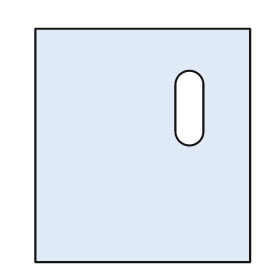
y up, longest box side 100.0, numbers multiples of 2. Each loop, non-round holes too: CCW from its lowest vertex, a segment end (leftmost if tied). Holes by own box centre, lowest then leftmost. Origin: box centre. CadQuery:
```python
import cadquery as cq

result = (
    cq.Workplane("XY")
    .moveTo(-46.0, -50.0)
    .lineTo(46.0, -50.0)
    .lineTo(46.0, 50.0)
    .lineTo(-46.0, 50.0)
    .close()
    .moveTo(14.0, 6.0)
    .threePointArc((20.0, 0.0), (26.0, 6.0))
    .lineTo(26.0, 26.0)
    .threePointArc((20.0, 32.0), (14.0, 26.0))
    .close()
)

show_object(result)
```